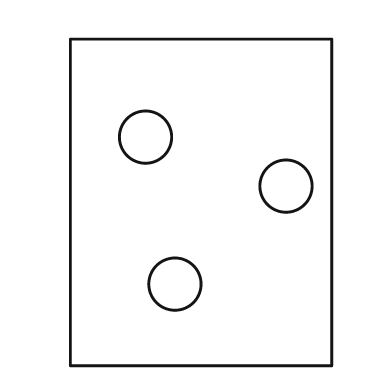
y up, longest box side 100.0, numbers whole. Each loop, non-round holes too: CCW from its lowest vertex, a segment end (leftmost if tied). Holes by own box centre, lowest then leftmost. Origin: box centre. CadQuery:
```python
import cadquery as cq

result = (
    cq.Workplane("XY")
    .moveTo(-40.0, -50.0)
    .lineTo(40.0, -50.0)
    .lineTo(40.0, 50.0)
    .lineTo(-40.0, 50.0)
    .close()
    .moveTo(-8.0, -25.0)
    .circle(8.0)
    .moveTo(26.0, 5.0)
    .circle(8.0)
    .moveTo(-17.0, 20.0)
    .circle(8.0)
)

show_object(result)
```